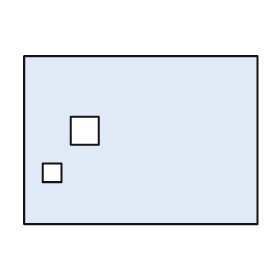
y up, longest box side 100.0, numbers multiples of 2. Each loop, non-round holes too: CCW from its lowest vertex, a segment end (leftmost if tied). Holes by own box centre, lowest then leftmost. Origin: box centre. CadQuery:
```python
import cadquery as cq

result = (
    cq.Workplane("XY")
    .moveTo(-50.0, -36.0)
    .lineTo(50.0, -36.0)
    .lineTo(50.0, 36.0)
    .lineTo(-50.0, 36.0)
    .close()
    .moveTo(-42.0, -18.0)
    .lineTo(-34.0, -18.0)
    .lineTo(-34.0, -10.0)
    .lineTo(-42.0, -10.0)
    .close()
    .moveTo(-30.0, -2.0)
    .lineTo(-18.0, -2.0)
    .lineTo(-18.0, 10.0)
    .lineTo(-30.0, 10.0)
    .close()
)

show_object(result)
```